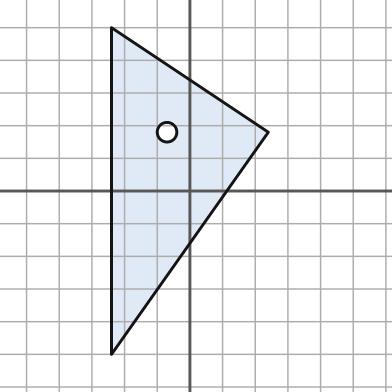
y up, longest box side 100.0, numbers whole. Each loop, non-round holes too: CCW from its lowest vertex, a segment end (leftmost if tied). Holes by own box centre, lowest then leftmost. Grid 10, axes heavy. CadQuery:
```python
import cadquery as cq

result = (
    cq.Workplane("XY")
    .moveTo(-24.0, -50.0)
    .lineTo(24.0, 18.0)
    .lineTo(-24.0, 50.0)
    .close()
    .moveTo(-7.0, 18.0)
    .circle(3.0)
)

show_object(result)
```